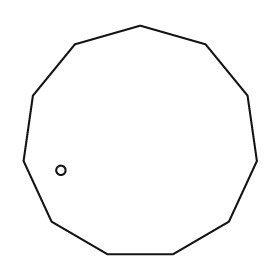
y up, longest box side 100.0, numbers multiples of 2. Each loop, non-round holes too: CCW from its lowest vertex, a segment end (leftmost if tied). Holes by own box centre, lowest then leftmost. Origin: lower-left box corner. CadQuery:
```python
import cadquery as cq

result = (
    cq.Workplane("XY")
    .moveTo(36.0, 0.0)
    .lineTo(64.0, 0.0)
    .lineTo(88.0, 14.0)
    .lineTo(100.0, 40.0)
    .lineTo(96.0, 68.0)
    .lineTo(78.0, 90.0)
    .lineTo(50.0, 98.0)
    .lineTo(22.0, 90.0)
    .lineTo(4.0, 68.0)
    .lineTo(0.0, 40.0)
    .lineTo(12.0, 14.0)
    .close()
    .moveTo(16.0, 36.0)
    .circle(2.0)
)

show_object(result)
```